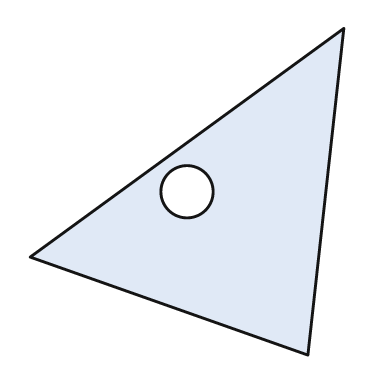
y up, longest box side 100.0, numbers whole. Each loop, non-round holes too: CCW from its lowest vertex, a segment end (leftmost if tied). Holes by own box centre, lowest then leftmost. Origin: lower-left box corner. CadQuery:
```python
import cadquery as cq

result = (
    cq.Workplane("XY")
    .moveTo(85.0, 0.0)
    .lineTo(96.0, 100.0)
    .lineTo(0.0, 30.0)
    .close()
    .moveTo(48.0, 50.0)
    .circle(8.0)
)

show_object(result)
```